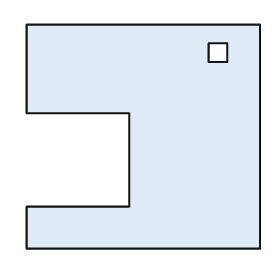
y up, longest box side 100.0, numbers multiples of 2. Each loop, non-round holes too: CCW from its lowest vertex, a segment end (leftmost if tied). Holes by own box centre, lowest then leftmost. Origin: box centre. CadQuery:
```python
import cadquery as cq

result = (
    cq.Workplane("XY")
    .moveTo(-50.0, -48.0)
    .lineTo(50.0, -48.0)
    .lineTo(50.0, 48.0)
    .lineTo(-50.0, 48.0)
    .lineTo(-50.0, 10.0)
    .lineTo(-6.0, 10.0)
    .lineTo(-6.0, -30.0)
    .lineTo(-50.0, -30.0)
    .close()
    .moveTo(28.0, 32.0)
    .lineTo(36.0, 32.0)
    .lineTo(36.0, 40.0)
    .lineTo(28.0, 40.0)
    .close()
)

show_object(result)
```